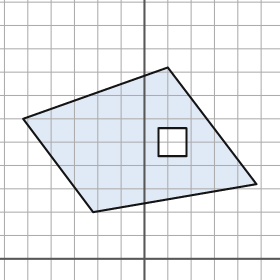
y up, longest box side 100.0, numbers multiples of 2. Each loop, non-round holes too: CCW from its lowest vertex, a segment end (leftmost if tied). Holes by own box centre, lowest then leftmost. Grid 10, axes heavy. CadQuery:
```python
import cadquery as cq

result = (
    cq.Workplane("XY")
    .moveTo(-22.0, 20.0)
    .lineTo(48.0, 32.0)
    .lineTo(10.0, 82.0)
    .lineTo(-52.0, 60.0)
    .close()
    .moveTo(6.0, 44.0)
    .lineTo(18.0, 44.0)
    .lineTo(18.0, 56.0)
    .lineTo(6.0, 56.0)
    .close()
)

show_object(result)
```